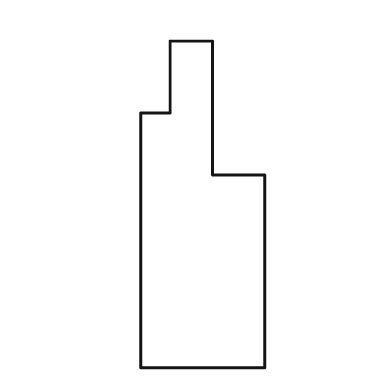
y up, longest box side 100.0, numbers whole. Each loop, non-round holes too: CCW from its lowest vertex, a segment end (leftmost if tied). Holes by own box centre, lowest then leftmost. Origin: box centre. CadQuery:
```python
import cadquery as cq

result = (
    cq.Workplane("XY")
    .moveTo(-19.0, -50.0)
    .lineTo(19.0, -50.0)
    .lineTo(19.0, 9.0)
    .lineTo(3.0, 9.0)
    .lineTo(3.0, 50.0)
    .lineTo(-10.0, 50.0)
    .lineTo(-10.0, 28.0)
    .lineTo(-19.0, 28.0)
    .close()
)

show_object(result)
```